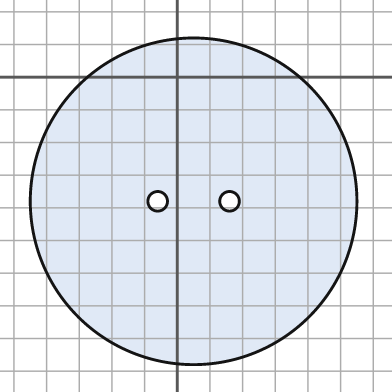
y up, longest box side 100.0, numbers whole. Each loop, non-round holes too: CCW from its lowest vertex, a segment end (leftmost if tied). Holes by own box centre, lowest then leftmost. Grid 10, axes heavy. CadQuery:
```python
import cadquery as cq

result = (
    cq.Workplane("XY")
    .moveTo(5.0, -38.0)
    .circle(50.0)
    .moveTo(-6.0, -38.0)
    .circle(3.0)
    .moveTo(16.0, -38.0)
    .circle(3.0)
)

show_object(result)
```